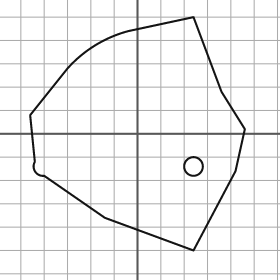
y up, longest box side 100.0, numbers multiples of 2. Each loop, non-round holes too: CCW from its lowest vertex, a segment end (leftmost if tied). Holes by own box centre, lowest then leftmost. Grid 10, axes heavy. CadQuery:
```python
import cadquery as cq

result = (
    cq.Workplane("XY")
    .moveTo(24.0, -50.0)
    .lineTo(42.0, -16.0)
    .lineTo(46.0, 2.0)
    .lineTo(36.0, 18.0)
    .lineTo(24.0, 50.0)
    .lineTo(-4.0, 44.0)
    .threePointArc((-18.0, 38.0), (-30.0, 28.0))
    .lineTo(-46.0, 8.0)
    .lineTo(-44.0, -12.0)
    .threePointArc((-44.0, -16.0), (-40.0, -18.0))
    .lineTo(-14.0, -36.0)
    .close()
    .moveTo(24.0, -14.0)
    .circle(4.0)
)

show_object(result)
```